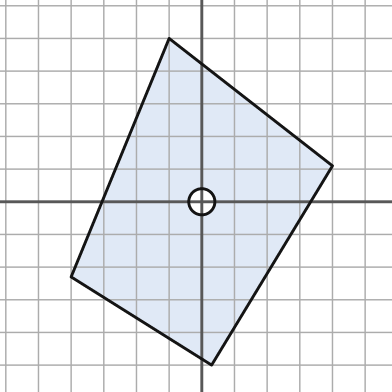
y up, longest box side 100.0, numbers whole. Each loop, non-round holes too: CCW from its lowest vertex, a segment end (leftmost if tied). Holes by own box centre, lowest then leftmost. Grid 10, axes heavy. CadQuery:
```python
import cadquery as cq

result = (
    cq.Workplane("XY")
    .moveTo(3.0, -50.0)
    .lineTo(40.0, 11.0)
    .lineTo(-10.0, 50.0)
    .lineTo(-40.0, -23.0)
    .close()
    .moveTo(0.0, 0.0)
    .circle(4.0)
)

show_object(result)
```